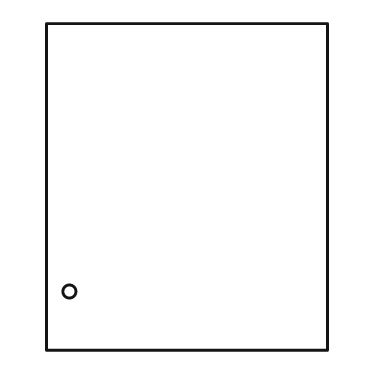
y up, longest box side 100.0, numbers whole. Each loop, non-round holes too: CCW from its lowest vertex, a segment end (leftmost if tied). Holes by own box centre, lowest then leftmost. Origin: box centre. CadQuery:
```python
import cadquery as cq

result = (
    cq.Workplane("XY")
    .moveTo(-43.0, -50.0)
    .lineTo(43.0, -50.0)
    .lineTo(43.0, 50.0)
    .lineTo(-43.0, 50.0)
    .close()
    .moveTo(-36.0, -32.0)
    .circle(2.0)
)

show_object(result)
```